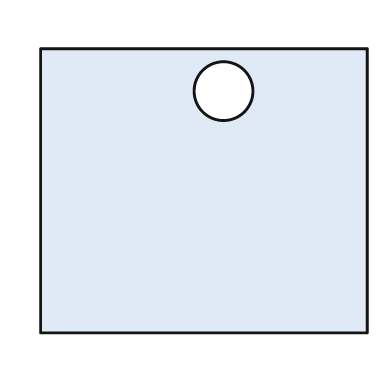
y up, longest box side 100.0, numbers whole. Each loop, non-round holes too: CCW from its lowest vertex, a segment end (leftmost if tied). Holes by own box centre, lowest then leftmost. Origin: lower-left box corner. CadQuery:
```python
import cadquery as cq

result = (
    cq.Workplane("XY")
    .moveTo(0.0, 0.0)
    .lineTo(100.0, 0.0)
    .lineTo(100.0, 87.0)
    .lineTo(0.0, 87.0)
    .close()
    .moveTo(56.0, 74.0)
    .circle(9.0)
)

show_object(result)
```